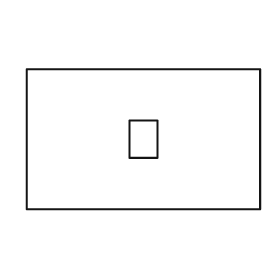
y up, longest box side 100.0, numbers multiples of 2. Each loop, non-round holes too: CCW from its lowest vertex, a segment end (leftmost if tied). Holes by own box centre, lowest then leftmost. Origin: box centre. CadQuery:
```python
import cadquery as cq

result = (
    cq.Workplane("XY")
    .moveTo(-50.0, -30.0)
    .lineTo(50.0, -30.0)
    .lineTo(50.0, 30.0)
    .lineTo(-50.0, 30.0)
    .close()
    .moveTo(-6.0, -8.0)
    .lineTo(6.0, -8.0)
    .lineTo(6.0, 8.0)
    .lineTo(-6.0, 8.0)
    .close()
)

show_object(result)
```